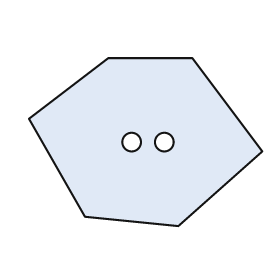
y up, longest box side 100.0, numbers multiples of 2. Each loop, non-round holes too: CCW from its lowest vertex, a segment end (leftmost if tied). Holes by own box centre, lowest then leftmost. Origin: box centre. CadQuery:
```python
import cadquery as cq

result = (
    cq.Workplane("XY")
    .moveTo(14.0, -36.0)
    .lineTo(50.0, -4.0)
    .lineTo(20.0, 36.0)
    .lineTo(-16.0, 36.0)
    .lineTo(-50.0, 10.0)
    .lineTo(-26.0, -32.0)
    .close()
    .moveTo(-6.0, 0.0)
    .circle(4.0)
    .moveTo(8.0, 0.0)
    .circle(4.0)
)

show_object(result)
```